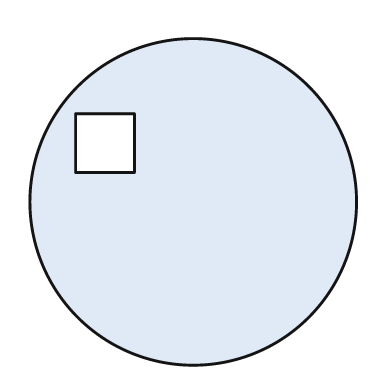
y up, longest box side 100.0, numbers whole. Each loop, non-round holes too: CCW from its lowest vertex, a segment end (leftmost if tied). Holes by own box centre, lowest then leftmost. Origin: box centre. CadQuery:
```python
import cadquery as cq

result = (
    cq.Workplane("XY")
    .moveTo(0.0, 0.0)
    .circle(50.0)
    .moveTo(-36.0, 9.0)
    .lineTo(-18.0, 9.0)
    .lineTo(-18.0, 27.0)
    .lineTo(-36.0, 27.0)
    .close()
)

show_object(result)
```